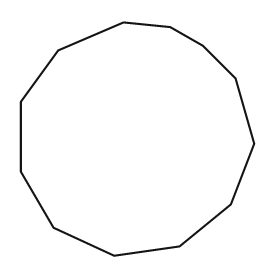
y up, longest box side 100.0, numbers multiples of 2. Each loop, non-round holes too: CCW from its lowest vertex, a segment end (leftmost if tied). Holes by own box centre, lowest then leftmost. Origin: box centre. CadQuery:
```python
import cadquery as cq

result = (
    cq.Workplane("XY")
    .moveTo(-10.0, -50.0)
    .lineTo(18.0, -46.0)
    .lineTo(40.0, -28.0)
    .lineTo(50.0, -2.0)
    .lineTo(42.0, 26.0)
    .lineTo(28.0, 40.0)
    .lineTo(14.0, 48.0)
    .lineTo(-6.0, 50.0)
    .lineTo(-34.0, 38.0)
    .lineTo(-50.0, 16.0)
    .lineTo(-50.0, -14.0)
    .lineTo(-36.0, -38.0)
    .close()
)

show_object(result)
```